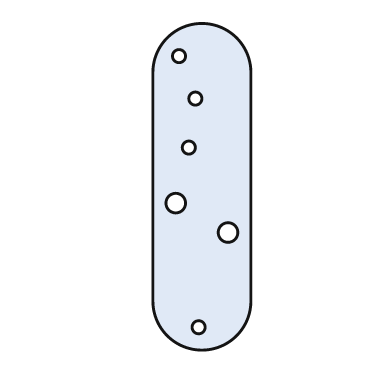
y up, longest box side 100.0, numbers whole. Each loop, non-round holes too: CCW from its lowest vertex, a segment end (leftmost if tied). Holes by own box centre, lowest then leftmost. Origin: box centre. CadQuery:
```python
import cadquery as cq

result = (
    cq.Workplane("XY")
    .moveTo(-15.0, -35.0)
    .threePointArc((0.0, -50.0), (15.0, -35.0))
    .lineTo(15.0, 35.0)
    .threePointArc((0.0, 50.0), (-15.0, 35.0))
    .close()
    .moveTo(-1.0, -43.0)
    .circle(2.0)
    .moveTo(8.0, -14.0)
    .circle(3.0)
    .moveTo(-8.0, -5.0)
    .circle(3.0)
    .moveTo(-4.0, 12.0)
    .circle(2.0)
    .moveTo(-2.0, 27.0)
    .circle(2.0)
    .moveTo(-7.0, 40.0)
    .circle(2.0)
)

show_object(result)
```